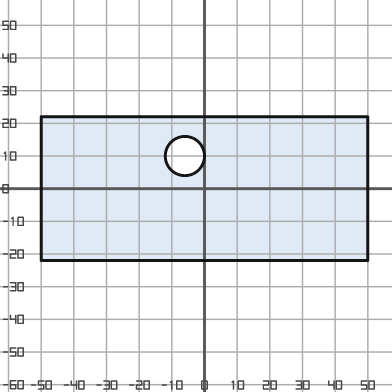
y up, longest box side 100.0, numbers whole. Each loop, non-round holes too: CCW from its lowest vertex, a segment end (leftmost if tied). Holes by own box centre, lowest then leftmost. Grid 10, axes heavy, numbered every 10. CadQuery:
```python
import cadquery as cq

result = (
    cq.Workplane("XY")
    .moveTo(-50.0, -22.0)
    .lineTo(50.0, -22.0)
    .lineTo(50.0, 22.0)
    .lineTo(-50.0, 22.0)
    .close()
    .moveTo(-6.0, 10.0)
    .circle(6.0)
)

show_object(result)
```